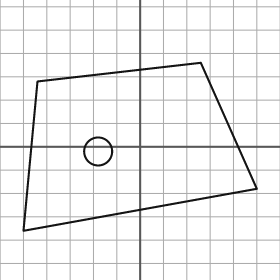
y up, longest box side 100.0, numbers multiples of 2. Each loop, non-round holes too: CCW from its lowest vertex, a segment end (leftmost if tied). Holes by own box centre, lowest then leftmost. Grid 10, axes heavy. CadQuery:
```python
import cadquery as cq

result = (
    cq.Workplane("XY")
    .moveTo(-50.0, -36.0)
    .lineTo(50.0, -18.0)
    .lineTo(26.0, 36.0)
    .lineTo(-44.0, 28.0)
    .close()
    .moveTo(-18.0, -2.0)
    .circle(6.0)
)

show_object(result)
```